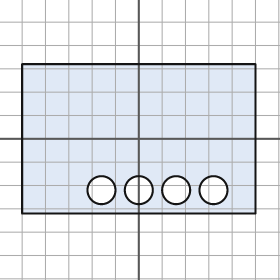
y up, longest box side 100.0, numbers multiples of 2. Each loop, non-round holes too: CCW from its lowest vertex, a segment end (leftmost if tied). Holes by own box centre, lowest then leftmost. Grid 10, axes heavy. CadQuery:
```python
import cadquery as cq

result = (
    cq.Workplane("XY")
    .moveTo(-50.0, -32.0)
    .lineTo(50.0, -32.0)
    .lineTo(50.0, 32.0)
    .lineTo(-50.0, 32.0)
    .close()
    .moveTo(-16.0, -22.0)
    .circle(6.0)
    .moveTo(0.0, -22.0)
    .circle(6.0)
    .moveTo(16.0, -22.0)
    .circle(6.0)
    .moveTo(32.0, -22.0)
    .circle(6.0)
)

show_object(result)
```